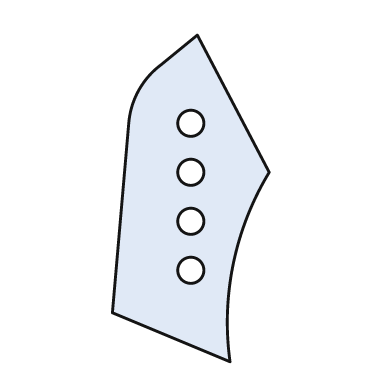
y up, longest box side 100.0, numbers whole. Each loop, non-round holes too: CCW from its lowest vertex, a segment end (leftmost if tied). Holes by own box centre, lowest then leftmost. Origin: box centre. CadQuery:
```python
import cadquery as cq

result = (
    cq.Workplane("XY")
    .moveTo(12.0, -50.0)
    .threePointArc((13.0, -20.0), (24.0, 8.0))
    .lineTo(2.0, 50.0)
    .lineTo(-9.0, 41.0)
    .threePointArc((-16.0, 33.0), (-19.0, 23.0))
    .lineTo(-24.0, -35.0)
    .close()
    .moveTo(0.0, -22.0)
    .circle(4.0)
    .moveTo(0.0, -7.0)
    .circle(4.0)
    .moveTo(0.0, 8.0)
    .circle(4.0)
    .moveTo(0.0, 23.0)
    .circle(4.0)
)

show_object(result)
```